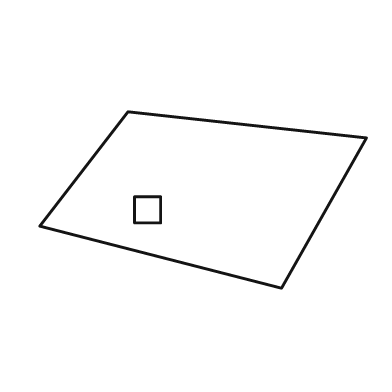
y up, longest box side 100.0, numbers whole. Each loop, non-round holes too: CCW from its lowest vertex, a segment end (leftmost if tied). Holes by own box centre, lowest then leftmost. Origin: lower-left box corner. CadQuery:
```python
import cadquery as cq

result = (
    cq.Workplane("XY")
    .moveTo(74.0, 0.0)
    .lineTo(100.0, 46.0)
    .lineTo(27.0, 54.0)
    .lineTo(0.0, 19.0)
    .close()
    .moveTo(29.0, 20.0)
    .lineTo(37.0, 20.0)
    .lineTo(37.0, 28.0)
    .lineTo(29.0, 28.0)
    .close()
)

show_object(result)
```